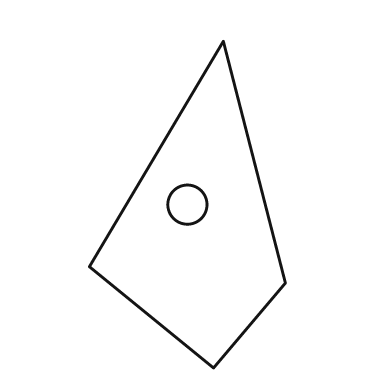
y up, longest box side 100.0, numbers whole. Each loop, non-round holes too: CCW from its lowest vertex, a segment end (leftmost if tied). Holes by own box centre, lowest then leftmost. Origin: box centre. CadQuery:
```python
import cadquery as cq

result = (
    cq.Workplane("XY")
    .moveTo(8.0, -50.0)
    .lineTo(30.0, -24.0)
    .lineTo(11.0, 50.0)
    .lineTo(-30.0, -19.0)
    .close()
    .moveTo(0.0, 0.0)
    .circle(6.0)
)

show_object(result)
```